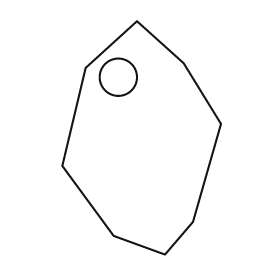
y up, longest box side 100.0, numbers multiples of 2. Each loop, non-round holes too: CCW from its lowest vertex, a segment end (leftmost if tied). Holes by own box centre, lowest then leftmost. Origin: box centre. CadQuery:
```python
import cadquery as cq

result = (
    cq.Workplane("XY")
    .moveTo(10.0, -50.0)
    .lineTo(22.0, -36.0)
    .lineTo(34.0, 6.0)
    .lineTo(18.0, 32.0)
    .lineTo(-2.0, 50.0)
    .lineTo(-24.0, 30.0)
    .lineTo(-34.0, -12.0)
    .lineTo(-12.0, -42.0)
    .close()
    .moveTo(-10.0, 26.0)
    .circle(8.0)
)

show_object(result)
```